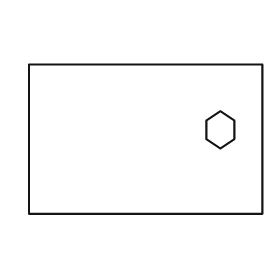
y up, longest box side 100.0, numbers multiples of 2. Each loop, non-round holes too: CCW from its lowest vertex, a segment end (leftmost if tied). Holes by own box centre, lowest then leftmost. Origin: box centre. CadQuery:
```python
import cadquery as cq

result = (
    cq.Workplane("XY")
    .moveTo(-50.0, -32.0)
    .lineTo(50.0, -32.0)
    .lineTo(50.0, 32.0)
    .lineTo(-50.0, 32.0)
    .close()
    .moveTo(32.0, -4.0)
    .lineTo(38.0, 0.0)
    .lineTo(38.0, 8.0)
    .lineTo(32.0, 12.0)
    .lineTo(26.0, 8.0)
    .lineTo(26.0, 0.0)
    .close()
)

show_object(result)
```